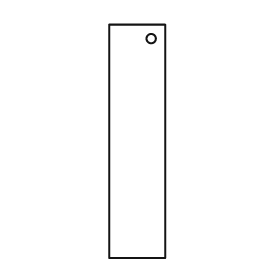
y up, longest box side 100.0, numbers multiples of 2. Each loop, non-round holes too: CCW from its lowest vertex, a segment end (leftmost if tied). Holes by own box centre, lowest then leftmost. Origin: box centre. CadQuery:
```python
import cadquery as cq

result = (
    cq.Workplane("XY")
    .moveTo(-12.0, -50.0)
    .lineTo(12.0, -50.0)
    .lineTo(12.0, 50.0)
    .lineTo(-12.0, 50.0)
    .close()
    .moveTo(6.0, 44.0)
    .circle(2.0)
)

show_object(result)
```